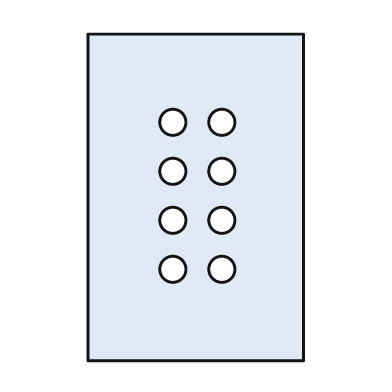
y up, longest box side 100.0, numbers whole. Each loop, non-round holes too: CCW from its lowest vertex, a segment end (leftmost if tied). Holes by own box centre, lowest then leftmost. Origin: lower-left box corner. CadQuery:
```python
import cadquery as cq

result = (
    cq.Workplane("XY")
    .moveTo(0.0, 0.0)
    .lineTo(66.0, 0.0)
    .lineTo(66.0, 100.0)
    .lineTo(0.0, 100.0)
    .close()
    .moveTo(26.0, 28.0)
    .circle(4.0)
    .moveTo(41.0, 28.0)
    .circle(4.0)
    .moveTo(26.0, 43.0)
    .circle(4.0)
    .moveTo(41.0, 43.0)
    .circle(4.0)
    .moveTo(26.0, 58.0)
    .circle(4.0)
    .moveTo(41.0, 58.0)
    .circle(4.0)
    .moveTo(26.0, 73.0)
    .circle(4.0)
    .moveTo(41.0, 73.0)
    .circle(4.0)
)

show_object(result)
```